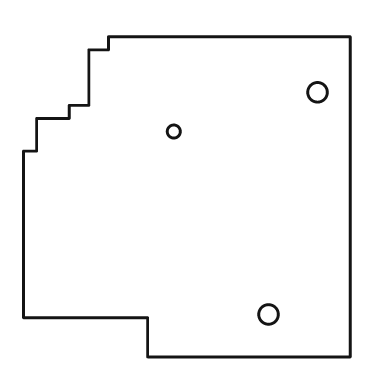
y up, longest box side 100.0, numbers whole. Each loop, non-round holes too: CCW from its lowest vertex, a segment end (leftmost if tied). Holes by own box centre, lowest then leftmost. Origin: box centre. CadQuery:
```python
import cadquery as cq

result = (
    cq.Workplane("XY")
    .moveTo(-12.0, -49.0)
    .lineTo(50.0, -49.0)
    .lineTo(50.0, 49.0)
    .lineTo(-24.0, 49.0)
    .lineTo(-24.0, 45.0)
    .lineTo(-30.0, 45.0)
    .lineTo(-30.0, 28.0)
    .lineTo(-36.0, 28.0)
    .lineTo(-36.0, 24.0)
    .lineTo(-46.0, 24.0)
    .lineTo(-46.0, 14.0)
    .lineTo(-50.0, 14.0)
    .lineTo(-50.0, -37.0)
    .lineTo(-12.0, -37.0)
    .close()
    .moveTo(25.0, -36.0)
    .circle(3.0)
    .moveTo(-4.0, 20.0)
    .circle(2.0)
    .moveTo(40.0, 32.0)
    .circle(3.0)
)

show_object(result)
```